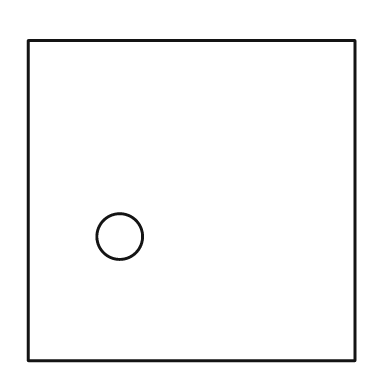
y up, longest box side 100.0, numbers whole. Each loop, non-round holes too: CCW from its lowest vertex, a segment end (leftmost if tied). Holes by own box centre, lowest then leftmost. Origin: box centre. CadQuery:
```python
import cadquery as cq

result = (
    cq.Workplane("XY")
    .moveTo(-50.0, -49.0)
    .lineTo(50.0, -49.0)
    .lineTo(50.0, 49.0)
    .lineTo(-50.0, 49.0)
    .close()
    .moveTo(-22.0, -11.0)
    .circle(7.0)
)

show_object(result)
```